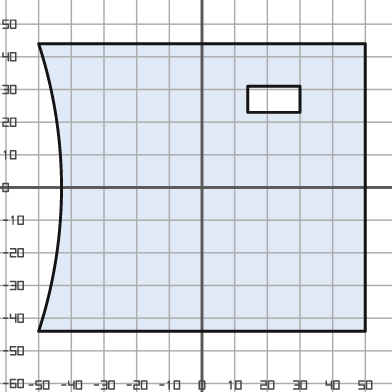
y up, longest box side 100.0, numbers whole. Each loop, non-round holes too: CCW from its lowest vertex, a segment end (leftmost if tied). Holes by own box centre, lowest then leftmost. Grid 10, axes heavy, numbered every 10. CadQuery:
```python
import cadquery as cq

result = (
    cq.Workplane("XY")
    .moveTo(-50.0, -44.0)
    .lineTo(50.0, -44.0)
    .lineTo(50.0, 44.0)
    .lineTo(-50.0, 44.0)
    .threePointArc((-43.0, 0.0), (-50.0, -44.0))
    .close()
    .moveTo(14.0, 23.0)
    .lineTo(30.0, 23.0)
    .lineTo(30.0, 31.0)
    .lineTo(14.0, 31.0)
    .close()
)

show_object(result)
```